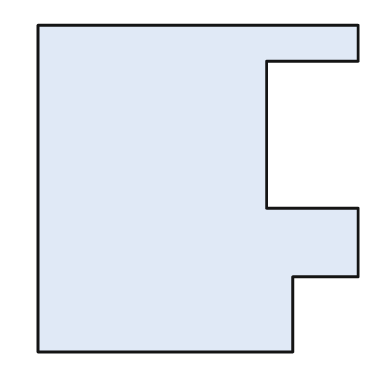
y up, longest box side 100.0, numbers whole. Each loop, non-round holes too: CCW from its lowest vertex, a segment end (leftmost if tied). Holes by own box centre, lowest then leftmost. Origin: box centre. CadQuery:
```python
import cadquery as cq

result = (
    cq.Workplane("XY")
    .moveTo(-49.0, -50.0)
    .lineTo(29.0, -50.0)
    .lineTo(29.0, -27.0)
    .lineTo(49.0, -27.0)
    .lineTo(49.0, -6.0)
    .lineTo(21.0, -6.0)
    .lineTo(21.0, 39.0)
    .lineTo(49.0, 39.0)
    .lineTo(49.0, 50.0)
    .lineTo(-49.0, 50.0)
    .close()
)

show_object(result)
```